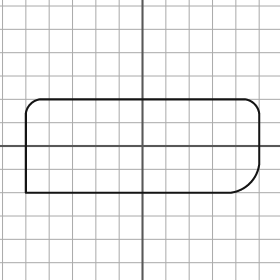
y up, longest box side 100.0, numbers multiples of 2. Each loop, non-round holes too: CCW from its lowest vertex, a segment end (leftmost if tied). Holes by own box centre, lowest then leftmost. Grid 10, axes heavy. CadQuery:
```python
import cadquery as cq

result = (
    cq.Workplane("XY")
    .moveTo(-50.0, -20.0)
    .lineTo(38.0, -20.0)
    .threePointArc((46.0, -16.0), (50.0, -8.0))
    .lineTo(50.0, 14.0)
    .threePointArc((48.0, 18.0), (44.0, 20.0))
    .lineTo(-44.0, 20.0)
    .threePointArc((-48.0, 18.0), (-50.0, 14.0))
    .close()
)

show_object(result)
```